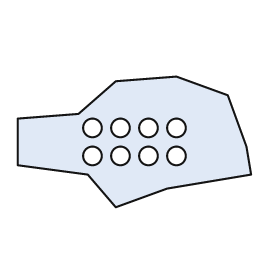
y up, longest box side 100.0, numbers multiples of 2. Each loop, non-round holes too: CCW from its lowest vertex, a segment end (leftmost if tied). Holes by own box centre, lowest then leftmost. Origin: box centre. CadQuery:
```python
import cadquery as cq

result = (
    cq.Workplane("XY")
    .moveTo(-8.0, -28.0)
    .lineTo(14.0, -20.0)
    .lineTo(50.0, -14.0)
    .lineTo(48.0, -2.0)
    .lineTo(40.0, 20.0)
    .lineTo(18.0, 28.0)
    .lineTo(-8.0, 26.0)
    .lineTo(-24.0, 12.0)
    .lineTo(-50.0, 10.0)
    .lineTo(-50.0, -10.0)
    .lineTo(-20.0, -14.0)
    .close()
    .moveTo(-18.0, -6.0)
    .circle(4.0)
    .moveTo(-6.0, -6.0)
    .circle(4.0)
    .moveTo(6.0, -6.0)
    .circle(4.0)
    .moveTo(18.0, -6.0)
    .circle(4.0)
    .moveTo(-18.0, 6.0)
    .circle(4.0)
    .moveTo(-6.0, 6.0)
    .circle(4.0)
    .moveTo(6.0, 6.0)
    .circle(4.0)
    .moveTo(18.0, 6.0)
    .circle(4.0)
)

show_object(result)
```